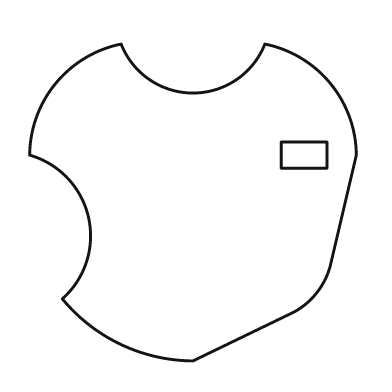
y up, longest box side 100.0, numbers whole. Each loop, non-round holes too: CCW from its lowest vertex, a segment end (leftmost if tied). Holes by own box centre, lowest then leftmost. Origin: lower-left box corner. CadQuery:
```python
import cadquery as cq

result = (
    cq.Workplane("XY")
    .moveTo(50.0, 0.0)
    .lineTo(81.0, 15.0)
    .threePointArc((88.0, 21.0), (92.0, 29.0))
    .lineTo(100.0, 63.0)
    .threePointArc((92.0, 85.0), (72.0, 97.0))
    .threePointArc((50.0, 82.0), (28.0, 97.0))
    .threePointArc((8.0, 85.0), (0.0, 63.0))
    .threePointArc((18.0, 44.0), (10.0, 19.0))
    .threePointArc((28.0, 5.0), (50.0, 0.0))
    .close()
    .moveTo(77.0, 59.0)
    .lineTo(91.0, 59.0)
    .lineTo(91.0, 67.0)
    .lineTo(77.0, 67.0)
    .close()
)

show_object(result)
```